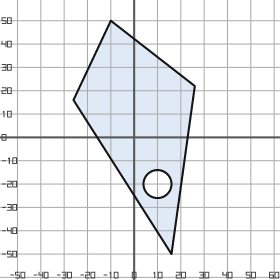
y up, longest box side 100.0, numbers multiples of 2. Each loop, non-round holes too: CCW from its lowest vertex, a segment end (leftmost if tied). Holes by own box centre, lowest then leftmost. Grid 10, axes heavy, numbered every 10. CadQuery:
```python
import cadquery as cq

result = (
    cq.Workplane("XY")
    .moveTo(16.0, -50.0)
    .lineTo(26.0, 22.0)
    .lineTo(-10.0, 50.0)
    .lineTo(-26.0, 16.0)
    .close()
    .moveTo(10.0, -20.0)
    .circle(6.0)
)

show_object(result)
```